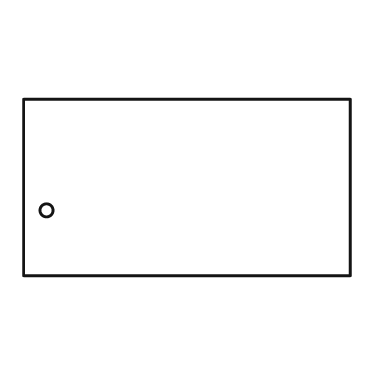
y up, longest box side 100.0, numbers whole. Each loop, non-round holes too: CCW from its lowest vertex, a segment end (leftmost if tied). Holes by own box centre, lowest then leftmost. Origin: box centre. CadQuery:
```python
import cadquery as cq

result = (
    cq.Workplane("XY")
    .moveTo(-50.0, -27.0)
    .lineTo(50.0, -27.0)
    .lineTo(50.0, 27.0)
    .lineTo(-50.0, 27.0)
    .close()
    .moveTo(-43.0, -7.0)
    .circle(2.0)
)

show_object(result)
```